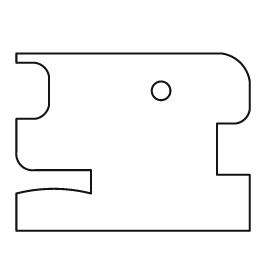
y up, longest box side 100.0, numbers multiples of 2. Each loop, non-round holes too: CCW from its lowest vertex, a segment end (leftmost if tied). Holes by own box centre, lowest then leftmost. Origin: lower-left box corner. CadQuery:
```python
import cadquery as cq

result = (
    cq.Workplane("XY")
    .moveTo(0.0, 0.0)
    .lineTo(100.0, 0.0)
    .lineTo(100.0, 24.0)
    .lineTo(86.0, 24.0)
    .lineTo(86.0, 46.0)
    .lineTo(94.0, 46.0)
    .threePointArc((98.0, 48.0), (100.0, 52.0))
    .lineTo(100.0, 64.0)
    .threePointArc((96.0, 72.0), (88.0, 76.0))
    .lineTo(0.0, 76.0)
    .lineTo(0.0, 72.0)
    .lineTo(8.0, 72.0)
    .threePointArc((12.0, 70.0), (14.0, 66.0))
    .lineTo(14.0, 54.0)
    .threePointArc((12.0, 50.0), (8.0, 48.0))
    .lineTo(0.0, 48.0)
    .lineTo(0.0, 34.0)
    .threePointArc((2.0, 28.0), (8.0, 26.0))
    .lineTo(32.0, 26.0)
    .lineTo(32.0, 16.0)
    .threePointArc((16.0, 18.0), (0.0, 16.0))
    .close()
    .moveTo(62.0, 60.0)
    .circle(4.0)
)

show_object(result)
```